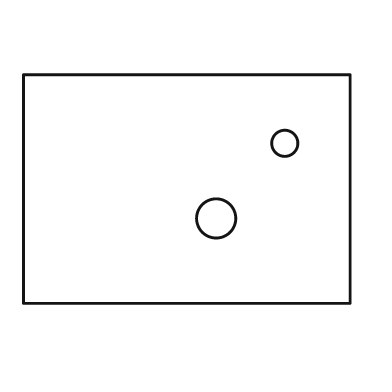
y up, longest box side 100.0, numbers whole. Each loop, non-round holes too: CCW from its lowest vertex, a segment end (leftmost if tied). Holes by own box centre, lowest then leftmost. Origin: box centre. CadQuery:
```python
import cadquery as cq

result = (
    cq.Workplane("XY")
    .moveTo(-50.0, -35.0)
    .lineTo(50.0, -35.0)
    .lineTo(50.0, 35.0)
    .lineTo(-50.0, 35.0)
    .close()
    .moveTo(9.0, -9.0)
    .circle(6.0)
    .moveTo(30.0, 14.0)
    .circle(4.0)
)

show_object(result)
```